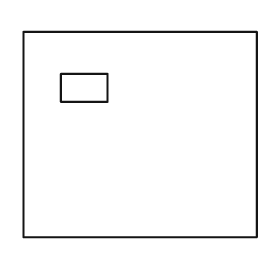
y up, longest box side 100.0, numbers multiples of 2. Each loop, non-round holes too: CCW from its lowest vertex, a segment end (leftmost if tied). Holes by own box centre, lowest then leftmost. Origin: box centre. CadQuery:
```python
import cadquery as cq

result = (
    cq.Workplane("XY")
    .moveTo(-50.0, -44.0)
    .lineTo(50.0, -44.0)
    .lineTo(50.0, 44.0)
    .lineTo(-50.0, 44.0)
    .close()
    .moveTo(-34.0, 14.0)
    .lineTo(-14.0, 14.0)
    .lineTo(-14.0, 26.0)
    .lineTo(-34.0, 26.0)
    .close()
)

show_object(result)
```